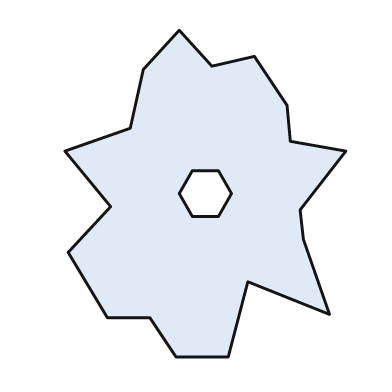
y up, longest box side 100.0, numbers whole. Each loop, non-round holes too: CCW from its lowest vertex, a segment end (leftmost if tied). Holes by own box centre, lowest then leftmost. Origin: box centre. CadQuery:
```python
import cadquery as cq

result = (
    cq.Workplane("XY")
    .moveTo(-9.0, -50.0)
    .lineTo(7.0, -50.0)
    .lineTo(13.0, -27.0)
    .lineTo(38.0, -37.0)
    .lineTo(30.0, -14.0)
    .lineTo(29.0, -5.0)
    .lineTo(43.0, 13.0)
    .lineTo(26.0, 16.0)
    .lineTo(25.0, 27.0)
    .lineTo(15.0, 42.0)
    .lineTo(2.0, 39.0)
    .lineTo(-8.0, 50.0)
    .lineTo(-19.0, 38.0)
    .lineTo(-23.0, 20.0)
    .lineTo(-43.0, 13.0)
    .lineTo(-29.0, -4.0)
    .lineTo(-42.0, -18.0)
    .lineTo(-30.0, -38.0)
    .lineTo(-17.0, -38.0)
    .close()
    .moveTo(-4.0, -7.0)
    .lineTo(4.0, -7.0)
    .lineTo(8.0, 0.0)
    .lineTo(4.0, 7.0)
    .lineTo(-4.0, 7.0)
    .lineTo(-8.0, 0.0)
    .close()
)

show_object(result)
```